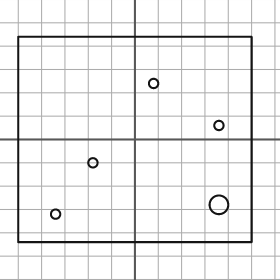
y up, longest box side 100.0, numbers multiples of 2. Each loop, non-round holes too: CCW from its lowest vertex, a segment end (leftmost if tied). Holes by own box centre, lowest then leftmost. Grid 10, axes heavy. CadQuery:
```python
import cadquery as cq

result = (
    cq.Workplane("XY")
    .moveTo(-50.0, -44.0)
    .lineTo(50.0, -44.0)
    .lineTo(50.0, 44.0)
    .lineTo(-50.0, 44.0)
    .close()
    .moveTo(-34.0, -32.0)
    .circle(2.0)
    .moveTo(36.0, -28.0)
    .circle(4.0)
    .moveTo(-18.0, -10.0)
    .circle(2.0)
    .moveTo(36.0, 6.0)
    .circle(2.0)
    .moveTo(8.0, 24.0)
    .circle(2.0)
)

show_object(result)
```